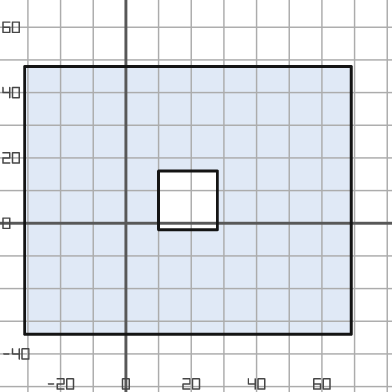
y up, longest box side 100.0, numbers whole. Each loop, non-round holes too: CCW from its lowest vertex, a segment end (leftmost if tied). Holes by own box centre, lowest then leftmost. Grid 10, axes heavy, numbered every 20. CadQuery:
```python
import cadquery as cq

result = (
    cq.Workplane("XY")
    .moveTo(-31.0, -34.0)
    .lineTo(69.0, -34.0)
    .lineTo(69.0, 48.0)
    .lineTo(-31.0, 48.0)
    .close()
    .moveTo(10.0, -2.0)
    .lineTo(28.0, -2.0)
    .lineTo(28.0, 16.0)
    .lineTo(10.0, 16.0)
    .close()
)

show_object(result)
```